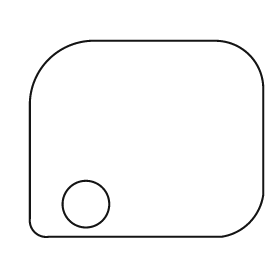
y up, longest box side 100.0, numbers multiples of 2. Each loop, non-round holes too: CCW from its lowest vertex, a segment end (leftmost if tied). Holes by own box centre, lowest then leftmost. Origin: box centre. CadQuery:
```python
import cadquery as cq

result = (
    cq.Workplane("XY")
    .moveTo(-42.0, -42.0)
    .lineTo(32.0, -42.0)
    .threePointArc((44.0, -36.0), (50.0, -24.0))
    .lineTo(50.0, 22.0)
    .threePointArc((44.0, 36.0), (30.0, 42.0))
    .lineTo(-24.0, 42.0)
    .threePointArc((-42.0, 34.0), (-50.0, 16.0))
    .lineTo(-50.0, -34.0)
    .threePointArc((-48.0, -40.0), (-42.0, -42.0))
    .close()
    .moveTo(-26.0, -28.0)
    .circle(10.0)
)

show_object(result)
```